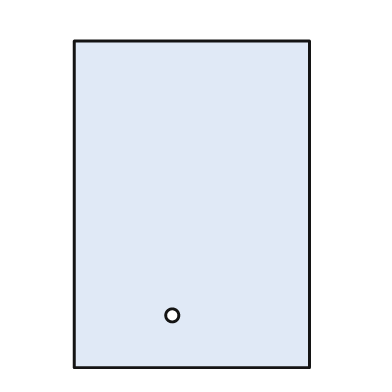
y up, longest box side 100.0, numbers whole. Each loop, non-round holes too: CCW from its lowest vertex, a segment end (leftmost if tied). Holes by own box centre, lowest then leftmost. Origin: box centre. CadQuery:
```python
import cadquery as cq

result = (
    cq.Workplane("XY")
    .moveTo(-36.0, -50.0)
    .lineTo(36.0, -50.0)
    .lineTo(36.0, 50.0)
    .lineTo(-36.0, 50.0)
    .close()
    .moveTo(-6.0, -34.0)
    .circle(2.0)
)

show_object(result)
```